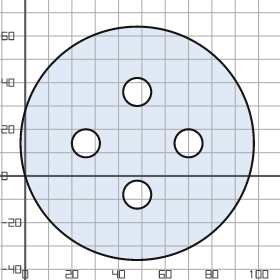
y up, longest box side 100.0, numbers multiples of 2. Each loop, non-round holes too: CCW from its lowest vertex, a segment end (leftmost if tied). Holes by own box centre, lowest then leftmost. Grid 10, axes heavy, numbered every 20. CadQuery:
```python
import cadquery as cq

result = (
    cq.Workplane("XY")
    .moveTo(48.0, 14.0)
    .circle(50.0)
    .moveTo(48.0, -8.0)
    .circle(6.0)
    .moveTo(26.0, 14.0)
    .circle(6.0)
    .moveTo(70.0, 14.0)
    .circle(6.0)
    .moveTo(48.0, 36.0)
    .circle(6.0)
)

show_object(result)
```